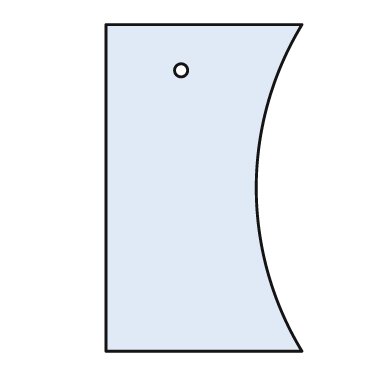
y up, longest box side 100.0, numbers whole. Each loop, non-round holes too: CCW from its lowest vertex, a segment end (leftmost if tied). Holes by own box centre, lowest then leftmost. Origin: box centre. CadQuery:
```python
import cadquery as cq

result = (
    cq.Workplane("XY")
    .moveTo(-30.0, -50.0)
    .lineTo(30.0, -50.0)
    .threePointArc((16.0, 0.0), (30.0, 50.0))
    .lineTo(-30.0, 50.0)
    .close()
    .moveTo(-7.0, 36.0)
    .circle(2.0)
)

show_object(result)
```